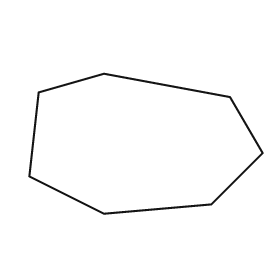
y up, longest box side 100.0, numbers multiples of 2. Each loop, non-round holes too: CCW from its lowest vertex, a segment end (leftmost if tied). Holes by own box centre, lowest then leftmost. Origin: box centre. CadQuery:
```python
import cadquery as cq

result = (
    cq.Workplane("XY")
    .moveTo(-18.0, -30.0)
    .lineTo(28.0, -26.0)
    .lineTo(50.0, -4.0)
    .lineTo(36.0, 20.0)
    .lineTo(-18.0, 30.0)
    .lineTo(-46.0, 22.0)
    .lineTo(-50.0, -14.0)
    .close()
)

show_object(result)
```